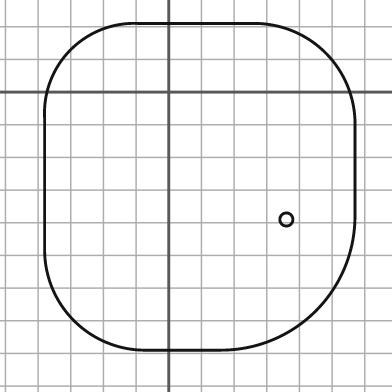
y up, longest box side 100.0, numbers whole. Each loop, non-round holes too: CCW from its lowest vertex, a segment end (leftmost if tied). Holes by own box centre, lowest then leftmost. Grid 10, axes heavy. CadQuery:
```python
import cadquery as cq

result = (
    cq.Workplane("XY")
    .moveTo(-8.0, -79.0)
    .lineTo(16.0, -79.0)
    .threePointArc((45.0, -67.0), (57.0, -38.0))
    .lineTo(57.0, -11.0)
    .threePointArc((48.0, 12.0), (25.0, 21.0))
    .lineTo(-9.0, 21.0)
    .threePointArc((-30.0, 13.0), (-38.0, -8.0))
    .lineTo(-38.0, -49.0)
    .threePointArc((-29.0, -70.0), (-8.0, -79.0))
    .close()
    .moveTo(36.0, -39.0)
    .circle(2.0)
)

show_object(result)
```